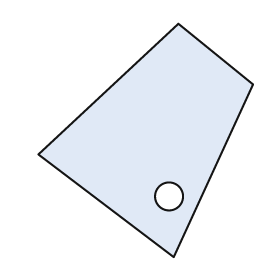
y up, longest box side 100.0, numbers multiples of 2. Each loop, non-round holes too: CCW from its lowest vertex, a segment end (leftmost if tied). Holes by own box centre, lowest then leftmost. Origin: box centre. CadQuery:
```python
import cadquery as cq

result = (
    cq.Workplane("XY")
    .moveTo(12.0, -50.0)
    .lineTo(46.0, 24.0)
    .lineTo(14.0, 50.0)
    .lineTo(-46.0, -6.0)
    .close()
    .moveTo(10.0, -24.0)
    .circle(6.0)
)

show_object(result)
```